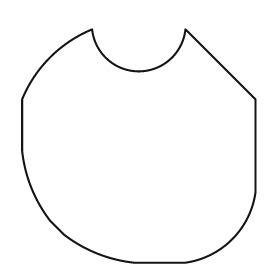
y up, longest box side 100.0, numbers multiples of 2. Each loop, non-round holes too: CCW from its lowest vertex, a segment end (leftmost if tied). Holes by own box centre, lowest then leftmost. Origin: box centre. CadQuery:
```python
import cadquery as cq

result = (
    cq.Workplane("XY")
    .moveTo(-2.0, -50.0)
    .lineTo(20.0, -50.0)
    .threePointArc((40.0, -40.0), (50.0, -20.0))
    .lineTo(50.0, 20.0)
    .lineTo(20.0, 50.0)
    .threePointArc((0.0, 32.0), (-20.0, 50.0))
    .threePointArc((-38.0, 38.0), (-50.0, 20.0))
    .lineTo(-50.0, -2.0)
    .threePointArc((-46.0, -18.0), (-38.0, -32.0))
    .lineTo(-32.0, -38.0)
    .threePointArc((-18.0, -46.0), (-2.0, -50.0))
    .close()
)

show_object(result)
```